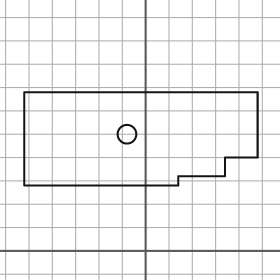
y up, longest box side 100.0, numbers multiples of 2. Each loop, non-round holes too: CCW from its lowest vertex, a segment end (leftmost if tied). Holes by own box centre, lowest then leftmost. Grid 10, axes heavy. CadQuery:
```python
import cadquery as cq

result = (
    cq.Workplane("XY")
    .moveTo(-52.0, 28.0)
    .lineTo(14.0, 28.0)
    .lineTo(14.0, 32.0)
    .lineTo(34.0, 32.0)
    .lineTo(34.0, 40.0)
    .lineTo(48.0, 40.0)
    .lineTo(48.0, 68.0)
    .lineTo(-52.0, 68.0)
    .close()
    .moveTo(-8.0, 50.0)
    .circle(4.0)
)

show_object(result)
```